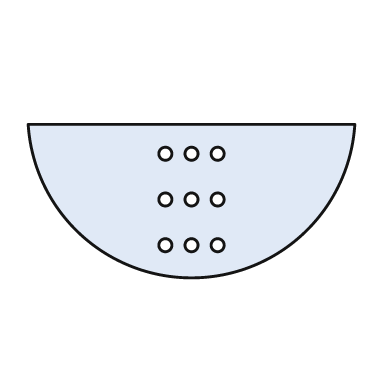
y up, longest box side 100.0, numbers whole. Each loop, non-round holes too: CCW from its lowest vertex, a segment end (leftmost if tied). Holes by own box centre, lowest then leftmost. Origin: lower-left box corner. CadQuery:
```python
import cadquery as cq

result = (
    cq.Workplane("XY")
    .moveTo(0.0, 47.0)
    .threePointArc((50.0, 0.0), (100.0, 47.0))
    .close()
    .moveTo(42.0, 10.0)
    .circle(2.0)
    .moveTo(50.0, 10.0)
    .circle(2.0)
    .moveTo(58.0, 10.0)
    .circle(2.0)
    .moveTo(42.0, 24.0)
    .circle(2.0)
    .moveTo(50.0, 24.0)
    .circle(2.0)
    .moveTo(58.0, 24.0)
    .circle(2.0)
    .moveTo(42.0, 38.0)
    .circle(2.0)
    .moveTo(50.0, 38.0)
    .circle(2.0)
    .moveTo(58.0, 38.0)
    .circle(2.0)
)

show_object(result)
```